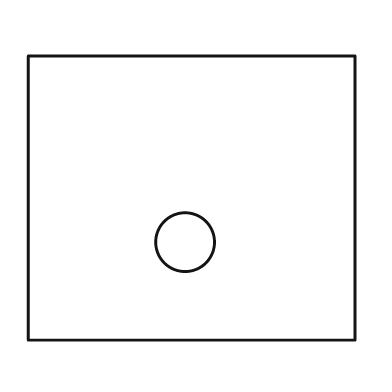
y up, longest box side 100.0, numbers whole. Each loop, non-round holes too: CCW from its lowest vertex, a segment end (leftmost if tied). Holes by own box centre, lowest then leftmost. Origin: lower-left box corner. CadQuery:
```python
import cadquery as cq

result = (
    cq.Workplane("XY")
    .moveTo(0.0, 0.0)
    .lineTo(100.0, 0.0)
    .lineTo(100.0, 87.0)
    .lineTo(0.0, 87.0)
    .close()
    .moveTo(48.0, 30.0)
    .circle(9.0)
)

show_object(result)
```